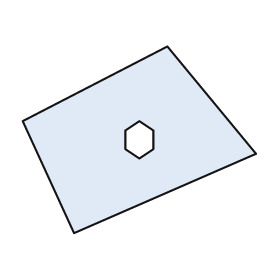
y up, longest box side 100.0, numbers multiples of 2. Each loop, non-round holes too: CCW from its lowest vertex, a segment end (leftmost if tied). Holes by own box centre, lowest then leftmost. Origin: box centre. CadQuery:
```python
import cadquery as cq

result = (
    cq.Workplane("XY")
    .moveTo(-28.0, -40.0)
    .lineTo(50.0, -6.0)
    .lineTo(12.0, 40.0)
    .lineTo(-50.0, 8.0)
    .close()
    .moveTo(0.0, -8.0)
    .lineTo(6.0, -4.0)
    .lineTo(6.0, 4.0)
    .lineTo(0.0, 8.0)
    .lineTo(-6.0, 4.0)
    .lineTo(-6.0, -4.0)
    .close()
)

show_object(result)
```